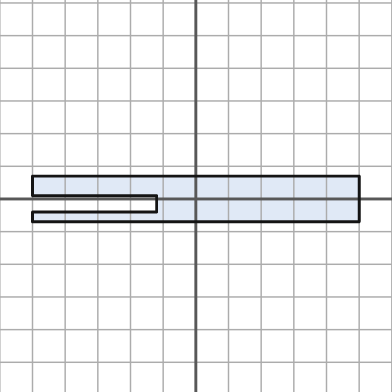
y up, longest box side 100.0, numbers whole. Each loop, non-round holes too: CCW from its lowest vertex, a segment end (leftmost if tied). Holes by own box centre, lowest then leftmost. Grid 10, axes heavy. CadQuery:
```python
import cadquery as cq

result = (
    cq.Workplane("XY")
    .moveTo(-50.0, -7.0)
    .lineTo(50.0, -7.0)
    .lineTo(50.0, 7.0)
    .lineTo(-50.0, 7.0)
    .lineTo(-50.0, 1.0)
    .lineTo(-12.0, 1.0)
    .lineTo(-12.0, -4.0)
    .lineTo(-50.0, -4.0)
    .close()
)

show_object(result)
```